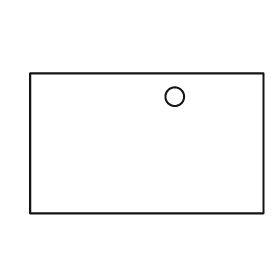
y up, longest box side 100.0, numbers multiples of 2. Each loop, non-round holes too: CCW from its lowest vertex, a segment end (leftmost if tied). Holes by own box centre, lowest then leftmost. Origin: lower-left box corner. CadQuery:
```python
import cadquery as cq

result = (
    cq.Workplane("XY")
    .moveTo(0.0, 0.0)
    .lineTo(100.0, 0.0)
    .lineTo(100.0, 60.0)
    .lineTo(0.0, 60.0)
    .close()
    .moveTo(62.0, 50.0)
    .circle(4.0)
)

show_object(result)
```